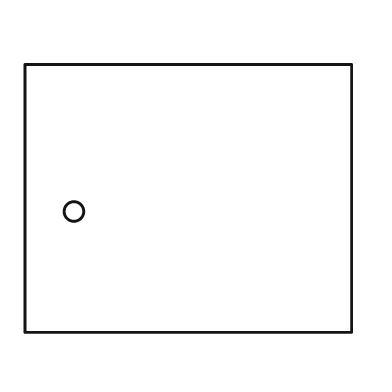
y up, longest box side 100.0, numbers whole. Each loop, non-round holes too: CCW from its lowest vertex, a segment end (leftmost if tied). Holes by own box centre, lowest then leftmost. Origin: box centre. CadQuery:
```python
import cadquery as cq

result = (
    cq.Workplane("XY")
    .moveTo(-50.0, -41.0)
    .lineTo(50.0, -41.0)
    .lineTo(50.0, 41.0)
    .lineTo(-50.0, 41.0)
    .close()
    .moveTo(-35.0, -4.0)
    .circle(3.0)
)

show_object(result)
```